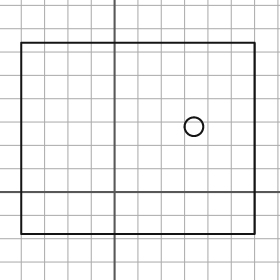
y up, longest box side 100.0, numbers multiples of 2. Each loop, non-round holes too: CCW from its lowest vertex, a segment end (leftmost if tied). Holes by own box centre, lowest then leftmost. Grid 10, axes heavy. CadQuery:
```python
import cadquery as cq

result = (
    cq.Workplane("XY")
    .moveTo(-40.0, -18.0)
    .lineTo(60.0, -18.0)
    .lineTo(60.0, 64.0)
    .lineTo(-40.0, 64.0)
    .close()
    .moveTo(34.0, 28.0)
    .circle(4.0)
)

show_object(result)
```